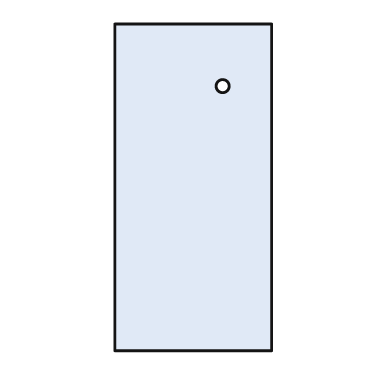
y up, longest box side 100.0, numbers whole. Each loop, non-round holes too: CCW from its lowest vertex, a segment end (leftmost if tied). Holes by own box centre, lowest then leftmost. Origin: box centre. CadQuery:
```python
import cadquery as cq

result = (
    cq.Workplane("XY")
    .moveTo(-24.0, -50.0)
    .lineTo(24.0, -50.0)
    .lineTo(24.0, 50.0)
    .lineTo(-24.0, 50.0)
    .close()
    .moveTo(9.0, 31.0)
    .circle(2.0)
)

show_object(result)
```